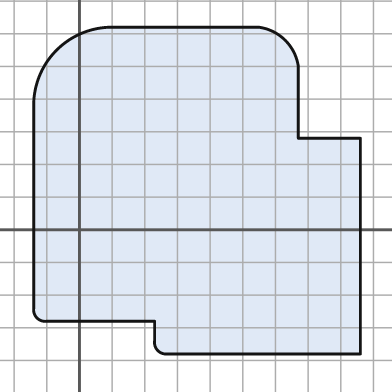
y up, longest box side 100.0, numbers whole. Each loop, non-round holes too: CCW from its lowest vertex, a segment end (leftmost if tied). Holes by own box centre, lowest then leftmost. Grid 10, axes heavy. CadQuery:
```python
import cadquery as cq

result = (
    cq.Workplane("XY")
    .moveTo(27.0, -38.0)
    .lineTo(86.0, -38.0)
    .lineTo(86.0, 28.0)
    .lineTo(67.0, 28.0)
    .lineTo(67.0, 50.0)
    .threePointArc((63.0, 58.0), (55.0, 62.0))
    .lineTo(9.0, 62.0)
    .threePointArc((-7.0, 55.0), (-14.0, 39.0))
    .lineTo(-14.0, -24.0)
    .threePointArc((-13.0, -27.0), (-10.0, -28.0))
    .lineTo(23.0, -28.0)
    .lineTo(23.0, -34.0)
    .threePointArc((24.0, -37.0), (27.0, -38.0))
    .close()
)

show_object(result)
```